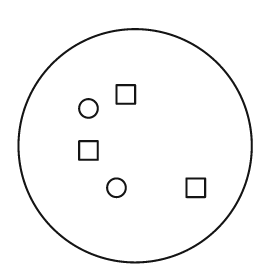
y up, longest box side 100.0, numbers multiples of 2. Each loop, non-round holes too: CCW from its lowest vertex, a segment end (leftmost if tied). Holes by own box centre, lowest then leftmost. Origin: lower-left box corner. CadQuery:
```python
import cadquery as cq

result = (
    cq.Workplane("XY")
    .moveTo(50.0, 50.0)
    .circle(50.0)
    .moveTo(42.0, 32.0)
    .circle(4.0)
    .moveTo(72.0, 28.0)
    .lineTo(80.0, 28.0)
    .lineTo(80.0, 36.0)
    .lineTo(72.0, 36.0)
    .close()
    .moveTo(26.0, 44.0)
    .lineTo(34.0, 44.0)
    .lineTo(34.0, 52.0)
    .lineTo(26.0, 52.0)
    .close()
    .moveTo(30.0, 66.0)
    .circle(4.0)
    .moveTo(42.0, 68.0)
    .lineTo(50.0, 68.0)
    .lineTo(50.0, 76.0)
    .lineTo(42.0, 76.0)
    .close()
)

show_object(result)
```